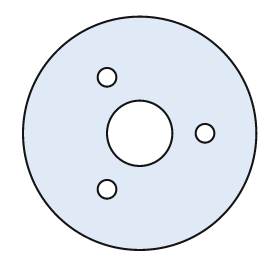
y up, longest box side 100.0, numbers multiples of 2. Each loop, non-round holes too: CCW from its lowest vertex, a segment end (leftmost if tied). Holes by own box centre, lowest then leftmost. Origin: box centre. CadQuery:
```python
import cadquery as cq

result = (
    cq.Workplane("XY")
    .moveTo(0.0, 0.0)
    .circle(50.0)
    .moveTo(-14.0, -24.0)
    .circle(4.0)
    .moveTo(0.0, 0.0)
    .circle(14.0)
    .moveTo(28.0, 0.0)
    .circle(4.0)
    .moveTo(-14.0, 24.0)
    .circle(4.0)
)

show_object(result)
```